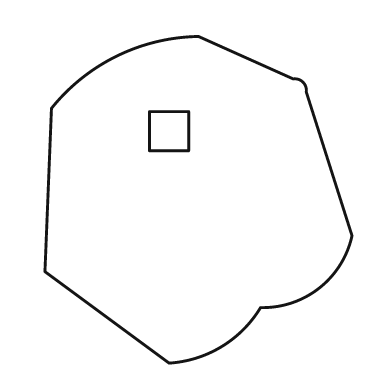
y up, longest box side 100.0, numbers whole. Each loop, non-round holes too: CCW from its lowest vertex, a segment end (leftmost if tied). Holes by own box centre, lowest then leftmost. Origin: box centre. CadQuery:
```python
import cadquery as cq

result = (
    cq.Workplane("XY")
    .moveTo(-9.0, -50.0)
    .threePointArc((7.0, -45.0), (19.0, -33.0))
    .threePointArc((37.0, -27.0), (47.0, -11.0))
    .lineTo(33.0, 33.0)
    .threePointArc((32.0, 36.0), (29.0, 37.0))
    .lineTo(0.0, 50.0)
    .threePointArc((-25.0, 44.0), (-45.0, 28.0))
    .lineTo(-47.0, -22.0)
    .close()
    .moveTo(-15.0, 15.0)
    .lineTo(-3.0, 15.0)
    .lineTo(-3.0, 27.0)
    .lineTo(-15.0, 27.0)
    .close()
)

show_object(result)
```